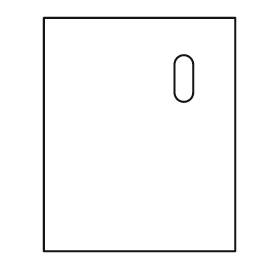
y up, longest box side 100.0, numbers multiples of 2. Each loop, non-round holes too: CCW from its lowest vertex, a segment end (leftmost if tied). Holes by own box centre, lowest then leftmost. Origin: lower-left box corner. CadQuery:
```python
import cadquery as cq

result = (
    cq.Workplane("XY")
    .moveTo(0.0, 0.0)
    .lineTo(82.0, 0.0)
    .lineTo(82.0, 100.0)
    .lineTo(0.0, 100.0)
    .close()
    .moveTo(56.0, 68.0)
    .threePointArc((60.0, 64.0), (64.0, 68.0))
    .lineTo(64.0, 80.0)
    .threePointArc((60.0, 84.0), (56.0, 80.0))
    .close()
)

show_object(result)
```